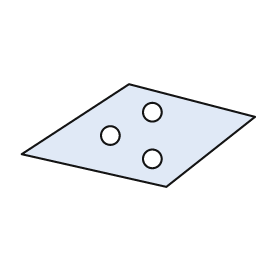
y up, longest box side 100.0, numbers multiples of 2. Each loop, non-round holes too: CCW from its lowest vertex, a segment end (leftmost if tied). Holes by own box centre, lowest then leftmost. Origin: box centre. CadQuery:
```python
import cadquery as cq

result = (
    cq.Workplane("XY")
    .moveTo(12.0, -22.0)
    .lineTo(50.0, 8.0)
    .lineTo(-4.0, 22.0)
    .lineTo(-50.0, -8.0)
    .close()
    .moveTo(6.0, -10.0)
    .circle(4.0)
    .moveTo(-12.0, 0.0)
    .circle(4.0)
    .moveTo(6.0, 10.0)
    .circle(4.0)
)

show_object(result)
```